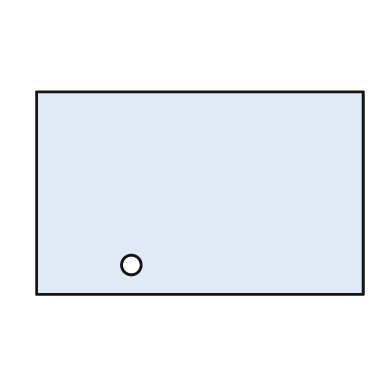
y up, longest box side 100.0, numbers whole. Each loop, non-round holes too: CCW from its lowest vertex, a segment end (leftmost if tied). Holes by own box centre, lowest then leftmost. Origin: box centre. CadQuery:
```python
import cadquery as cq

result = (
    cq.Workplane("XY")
    .moveTo(-50.0, -31.0)
    .lineTo(50.0, -31.0)
    .lineTo(50.0, 31.0)
    .lineTo(-50.0, 31.0)
    .close()
    .moveTo(-21.0, -22.0)
    .circle(3.0)
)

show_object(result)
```